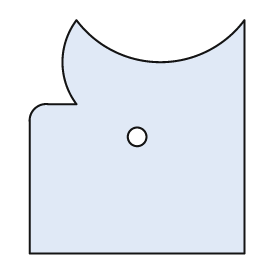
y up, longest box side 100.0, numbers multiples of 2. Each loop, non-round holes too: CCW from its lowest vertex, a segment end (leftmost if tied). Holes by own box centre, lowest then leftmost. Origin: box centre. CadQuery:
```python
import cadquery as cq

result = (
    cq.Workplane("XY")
    .moveTo(-46.0, -50.0)
    .lineTo(46.0, -50.0)
    .lineTo(46.0, 50.0)
    .threePointArc((10.0, 32.0), (-26.0, 50.0))
    .threePointArc((-32.0, 32.0), (-26.0, 14.0))
    .lineTo(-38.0, 14.0)
    .threePointArc((-44.0, 12.0), (-46.0, 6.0))
    .close()
    .moveTo(0.0, 0.0)
    .circle(4.0)
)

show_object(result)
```